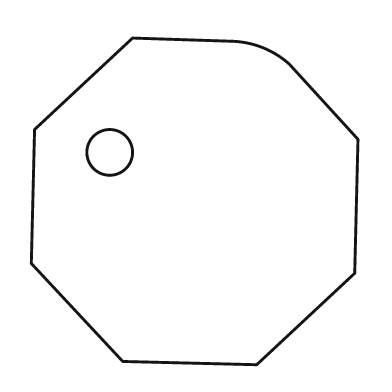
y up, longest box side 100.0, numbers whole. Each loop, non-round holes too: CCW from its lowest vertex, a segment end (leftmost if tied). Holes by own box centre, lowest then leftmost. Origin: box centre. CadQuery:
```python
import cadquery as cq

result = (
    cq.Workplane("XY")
    .moveTo(19.0, -50.0)
    .lineTo(49.0, -22.0)
    .lineTo(50.0, 19.0)
    .lineTo(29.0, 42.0)
    .threePointArc((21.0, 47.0), (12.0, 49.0))
    .lineTo(-19.0, 50.0)
    .lineTo(-49.0, 22.0)
    .lineTo(-50.0, -19.0)
    .lineTo(-22.0, -49.0)
    .close()
    .moveTo(-26.0, 15.0)
    .circle(7.0)
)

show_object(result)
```